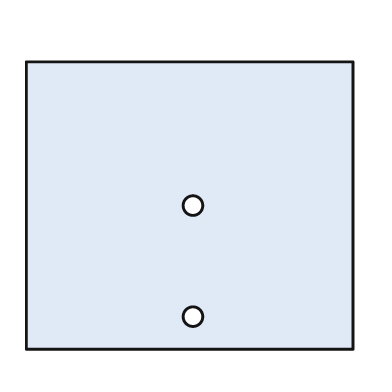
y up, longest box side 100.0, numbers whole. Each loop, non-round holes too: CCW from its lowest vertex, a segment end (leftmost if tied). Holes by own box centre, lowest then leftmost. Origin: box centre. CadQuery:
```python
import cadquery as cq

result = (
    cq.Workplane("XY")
    .moveTo(-50.0, -44.0)
    .lineTo(50.0, -44.0)
    .lineTo(50.0, 44.0)
    .lineTo(-50.0, 44.0)
    .close()
    .moveTo(1.0, -34.0)
    .circle(3.0)
    .moveTo(1.0, 0.0)
    .circle(3.0)
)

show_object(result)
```